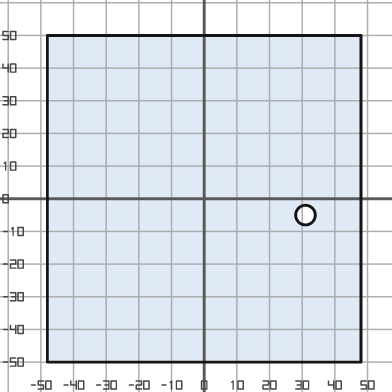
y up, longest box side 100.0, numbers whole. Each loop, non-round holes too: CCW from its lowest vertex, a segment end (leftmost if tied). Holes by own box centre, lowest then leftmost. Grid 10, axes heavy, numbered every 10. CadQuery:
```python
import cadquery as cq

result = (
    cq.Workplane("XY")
    .moveTo(-48.0, -50.0)
    .lineTo(48.0, -50.0)
    .lineTo(48.0, 50.0)
    .lineTo(-48.0, 50.0)
    .close()
    .moveTo(31.0, -5.0)
    .circle(3.0)
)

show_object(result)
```